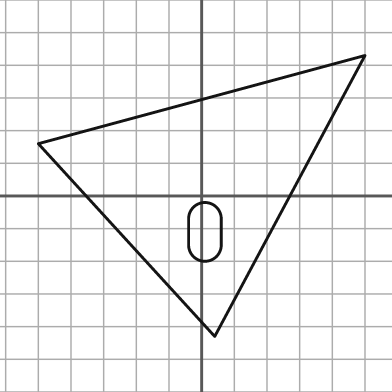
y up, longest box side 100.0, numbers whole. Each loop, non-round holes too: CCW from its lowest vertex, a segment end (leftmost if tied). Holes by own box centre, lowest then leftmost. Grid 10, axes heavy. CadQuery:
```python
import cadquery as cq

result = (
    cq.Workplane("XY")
    .moveTo(4.0, -43.0)
    .lineTo(50.0, 43.0)
    .lineTo(-50.0, 16.0)
    .close()
    .moveTo(-4.0, -15.0)
    .threePointArc((1.0, -20.0), (6.0, -15.0))
    .lineTo(6.0, -7.0)
    .threePointArc((1.0, -2.0), (-4.0, -7.0))
    .close()
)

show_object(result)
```